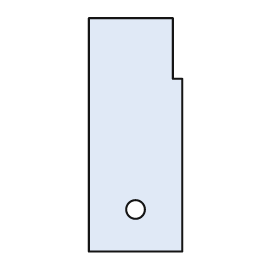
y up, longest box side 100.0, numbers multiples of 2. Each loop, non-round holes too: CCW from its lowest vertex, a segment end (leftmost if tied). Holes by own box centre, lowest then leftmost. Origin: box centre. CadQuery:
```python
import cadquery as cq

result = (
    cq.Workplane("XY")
    .moveTo(-20.0, -50.0)
    .lineTo(20.0, -50.0)
    .lineTo(20.0, 24.0)
    .lineTo(16.0, 24.0)
    .lineTo(16.0, 50.0)
    .lineTo(-20.0, 50.0)
    .close()
    .moveTo(0.0, -32.0)
    .circle(4.0)
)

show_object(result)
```